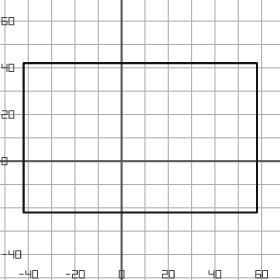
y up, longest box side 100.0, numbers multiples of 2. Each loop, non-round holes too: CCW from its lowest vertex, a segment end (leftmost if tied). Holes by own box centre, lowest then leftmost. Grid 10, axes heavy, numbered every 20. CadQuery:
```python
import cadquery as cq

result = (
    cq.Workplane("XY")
    .moveTo(-42.0, -22.0)
    .lineTo(58.0, -22.0)
    .lineTo(58.0, 42.0)
    .lineTo(-42.0, 42.0)
    .close()
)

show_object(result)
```